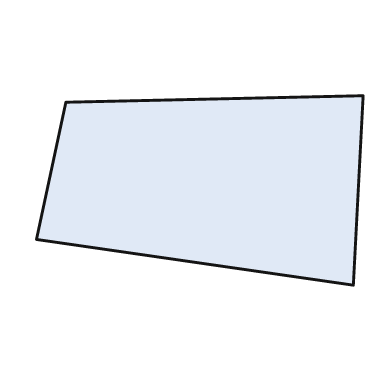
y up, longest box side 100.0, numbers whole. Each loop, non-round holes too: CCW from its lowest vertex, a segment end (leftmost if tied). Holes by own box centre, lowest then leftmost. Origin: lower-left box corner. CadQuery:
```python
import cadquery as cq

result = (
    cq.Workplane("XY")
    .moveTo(97.0, 0.0)
    .lineTo(100.0, 58.0)
    .lineTo(9.0, 56.0)
    .lineTo(0.0, 14.0)
    .close()
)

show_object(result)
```